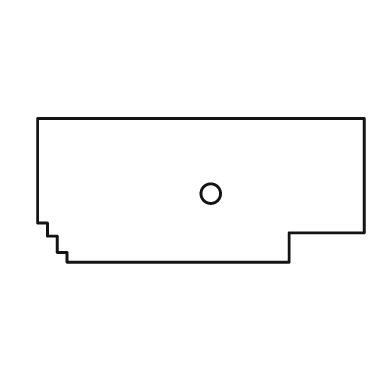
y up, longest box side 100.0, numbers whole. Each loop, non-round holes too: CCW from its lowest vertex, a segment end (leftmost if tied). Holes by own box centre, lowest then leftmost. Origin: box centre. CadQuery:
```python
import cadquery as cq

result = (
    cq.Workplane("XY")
    .moveTo(-41.0, -22.0)
    .lineTo(27.0, -22.0)
    .lineTo(27.0, -13.0)
    .lineTo(50.0, -13.0)
    .lineTo(50.0, 22.0)
    .lineTo(-50.0, 22.0)
    .lineTo(-50.0, -10.0)
    .lineTo(-47.0, -10.0)
    .lineTo(-47.0, -14.0)
    .lineTo(-44.0, -14.0)
    .lineTo(-44.0, -19.0)
    .lineTo(-41.0, -19.0)
    .close()
    .moveTo(3.0, -1.0)
    .circle(3.0)
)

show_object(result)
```